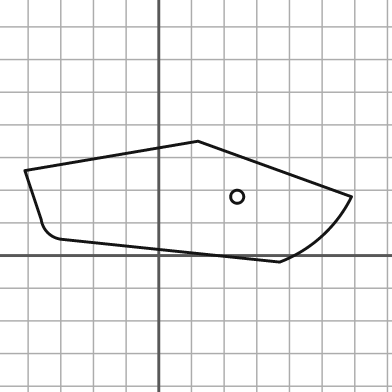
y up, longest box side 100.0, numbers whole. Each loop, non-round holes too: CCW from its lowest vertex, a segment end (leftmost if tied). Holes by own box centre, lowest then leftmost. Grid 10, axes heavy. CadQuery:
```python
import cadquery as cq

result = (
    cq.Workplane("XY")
    .moveTo(37.0, -2.0)
    .threePointArc((50.0, 6.0), (59.0, 18.0))
    .lineTo(12.0, 35.0)
    .lineTo(-41.0, 26.0)
    .lineTo(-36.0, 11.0)
    .threePointArc((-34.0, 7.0), (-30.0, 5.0))
    .close()
    .moveTo(24.0, 18.0)
    .circle(2.0)
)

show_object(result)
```